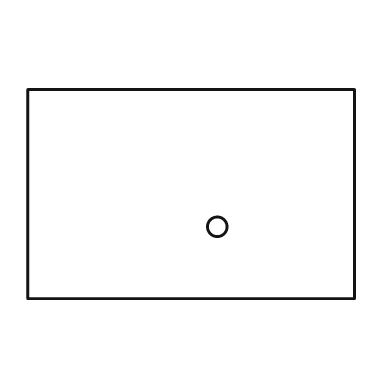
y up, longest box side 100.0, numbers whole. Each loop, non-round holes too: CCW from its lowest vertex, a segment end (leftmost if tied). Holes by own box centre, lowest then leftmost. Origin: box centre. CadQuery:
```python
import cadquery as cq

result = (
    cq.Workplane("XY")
    .moveTo(-50.0, -32.0)
    .lineTo(50.0, -32.0)
    .lineTo(50.0, 32.0)
    .lineTo(-50.0, 32.0)
    .close()
    .moveTo(8.0, -10.0)
    .circle(3.0)
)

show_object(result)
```